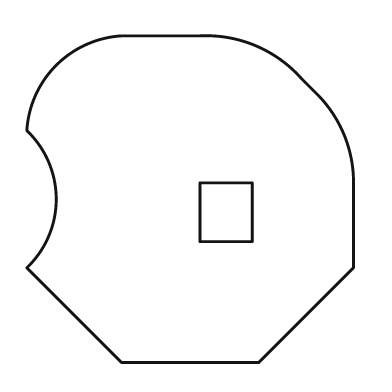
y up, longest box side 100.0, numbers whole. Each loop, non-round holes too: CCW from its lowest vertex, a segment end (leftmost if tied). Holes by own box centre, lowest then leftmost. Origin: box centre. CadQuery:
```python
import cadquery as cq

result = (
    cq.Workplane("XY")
    .moveTo(-21.0, -50.0)
    .lineTo(21.0, -50.0)
    .lineTo(50.0, -21.0)
    .lineTo(50.0, 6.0)
    .threePointArc((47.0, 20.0), (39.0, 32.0))
    .lineTo(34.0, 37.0)
    .threePointArc((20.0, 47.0), (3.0, 50.0))
    .lineTo(-21.0, 50.0)
    .threePointArc((-41.0, 41.0), (-50.0, 21.0))
    .threePointArc((-41.0, 0.0), (-50.0, -21.0))
    .close()
    .moveTo(3.0, -13.0)
    .lineTo(19.0, -13.0)
    .lineTo(19.0, 5.0)
    .lineTo(3.0, 5.0)
    .close()
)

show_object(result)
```